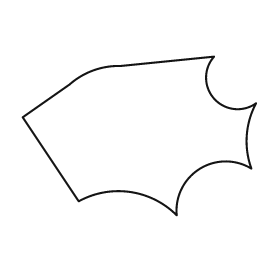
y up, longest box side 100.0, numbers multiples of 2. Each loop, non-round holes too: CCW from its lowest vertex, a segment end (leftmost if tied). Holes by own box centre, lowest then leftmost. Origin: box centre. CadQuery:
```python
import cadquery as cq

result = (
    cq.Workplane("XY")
    .moveTo(16.0, -34.0)
    .threePointArc((26.0, -14.0), (48.0, -14.0))
    .threePointArc((46.0, 0.0), (50.0, 14.0))
    .threePointArc((32.0, 16.0), (32.0, 34.0))
    .lineTo(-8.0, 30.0)
    .threePointArc((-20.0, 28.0), (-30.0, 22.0))
    .lineTo(-50.0, 8.0)
    .lineTo(-26.0, -28.0)
    .threePointArc((-4.0, -24.0), (16.0, -34.0))
    .close()
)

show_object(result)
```